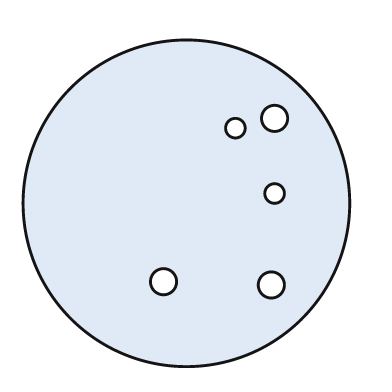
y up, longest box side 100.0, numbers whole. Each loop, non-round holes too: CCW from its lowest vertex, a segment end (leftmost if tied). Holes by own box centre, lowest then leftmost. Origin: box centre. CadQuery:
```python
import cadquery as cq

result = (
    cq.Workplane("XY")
    .moveTo(0.0, 0.0)
    .circle(50.0)
    .moveTo(26.0, -25.0)
    .circle(4.0)
    .moveTo(-7.0, -24.0)
    .circle(4.0)
    .moveTo(27.0, 3.0)
    .circle(3.0)
    .moveTo(15.0, 23.0)
    .circle(3.0)
    .moveTo(27.0, 26.0)
    .circle(4.0)
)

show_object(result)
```